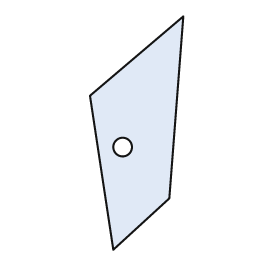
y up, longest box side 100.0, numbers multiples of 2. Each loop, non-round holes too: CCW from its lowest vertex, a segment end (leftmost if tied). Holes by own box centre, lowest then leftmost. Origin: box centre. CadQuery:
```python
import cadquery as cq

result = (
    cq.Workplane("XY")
    .moveTo(-10.0, -50.0)
    .lineTo(14.0, -28.0)
    .lineTo(20.0, 50.0)
    .lineTo(-20.0, 16.0)
    .close()
    .moveTo(-6.0, -6.0)
    .circle(4.0)
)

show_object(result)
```